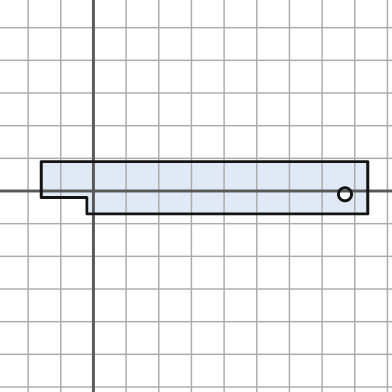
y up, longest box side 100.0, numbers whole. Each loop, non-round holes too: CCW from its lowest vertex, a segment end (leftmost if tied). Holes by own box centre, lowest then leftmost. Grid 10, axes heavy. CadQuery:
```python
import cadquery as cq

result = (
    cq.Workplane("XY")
    .moveTo(-2.0, -7.0)
    .lineTo(84.0, -7.0)
    .lineTo(84.0, 9.0)
    .lineTo(-16.0, 9.0)
    .lineTo(-16.0, -2.0)
    .lineTo(-2.0, -2.0)
    .close()
    .moveTo(77.0, -1.0)
    .circle(2.0)
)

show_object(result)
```